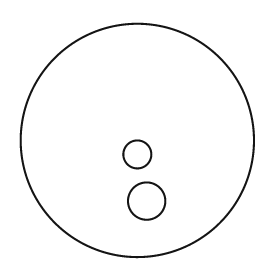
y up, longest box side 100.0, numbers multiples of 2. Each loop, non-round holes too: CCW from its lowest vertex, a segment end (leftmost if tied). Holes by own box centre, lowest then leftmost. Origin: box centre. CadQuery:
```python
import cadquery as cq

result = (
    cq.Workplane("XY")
    .moveTo(0.0, 0.0)
    .circle(50.0)
    .moveTo(4.0, -26.0)
    .circle(8.0)
    .moveTo(0.0, -6.0)
    .circle(6.0)
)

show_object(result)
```